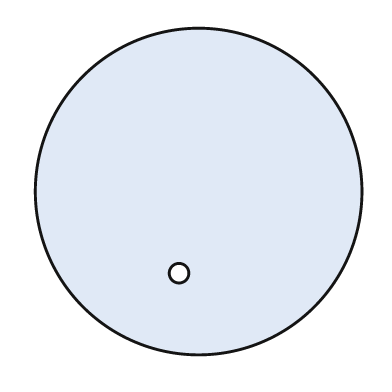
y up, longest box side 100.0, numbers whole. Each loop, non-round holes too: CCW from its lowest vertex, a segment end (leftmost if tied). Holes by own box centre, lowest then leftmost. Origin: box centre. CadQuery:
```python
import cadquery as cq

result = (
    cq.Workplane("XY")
    .moveTo(0.0, 0.0)
    .circle(50.0)
    .moveTo(-6.0, -25.0)
    .circle(3.0)
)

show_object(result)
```